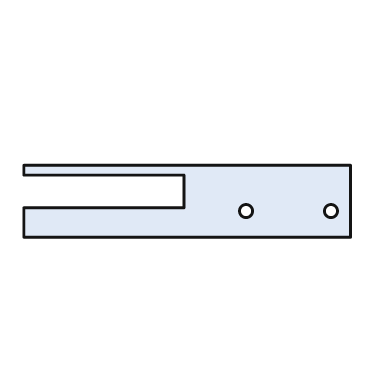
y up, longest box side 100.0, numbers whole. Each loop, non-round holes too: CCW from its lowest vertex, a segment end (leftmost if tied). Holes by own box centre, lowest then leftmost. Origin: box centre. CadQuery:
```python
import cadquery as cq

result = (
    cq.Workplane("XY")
    .moveTo(-50.0, -11.0)
    .lineTo(50.0, -11.0)
    .lineTo(50.0, 11.0)
    .lineTo(-50.0, 11.0)
    .lineTo(-50.0, 8.0)
    .lineTo(-1.0, 8.0)
    .lineTo(-1.0, -2.0)
    .lineTo(-50.0, -2.0)
    .close()
    .moveTo(18.0, -3.0)
    .circle(2.0)
    .moveTo(44.0, -3.0)
    .circle(2.0)
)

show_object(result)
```